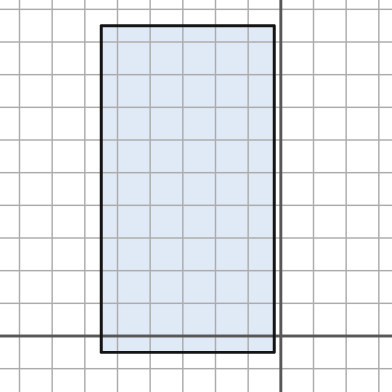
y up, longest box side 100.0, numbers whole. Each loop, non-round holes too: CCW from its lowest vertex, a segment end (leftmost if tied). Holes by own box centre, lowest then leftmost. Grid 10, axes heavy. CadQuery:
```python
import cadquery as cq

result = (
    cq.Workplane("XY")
    .moveTo(-55.0, -5.0)
    .lineTo(-2.0, -5.0)
    .lineTo(-2.0, 95.0)
    .lineTo(-55.0, 95.0)
    .close()
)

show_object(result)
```